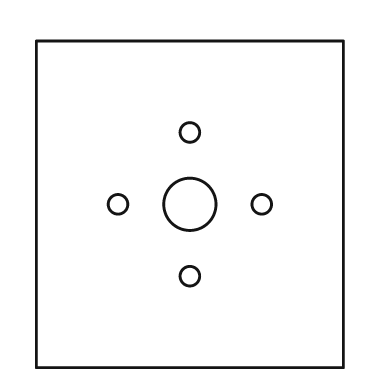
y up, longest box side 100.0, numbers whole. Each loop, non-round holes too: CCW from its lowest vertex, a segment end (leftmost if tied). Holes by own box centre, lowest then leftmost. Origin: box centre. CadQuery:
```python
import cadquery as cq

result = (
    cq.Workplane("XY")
    .moveTo(-47.0, -50.0)
    .lineTo(47.0, -50.0)
    .lineTo(47.0, 50.0)
    .lineTo(-47.0, 50.0)
    .close()
    .moveTo(0.0, -22.0)
    .circle(3.0)
    .moveTo(-22.0, 0.0)
    .circle(3.0)
    .moveTo(0.0, 0.0)
    .circle(8.0)
    .moveTo(22.0, 0.0)
    .circle(3.0)
    .moveTo(0.0, 22.0)
    .circle(3.0)
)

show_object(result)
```